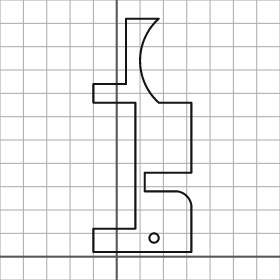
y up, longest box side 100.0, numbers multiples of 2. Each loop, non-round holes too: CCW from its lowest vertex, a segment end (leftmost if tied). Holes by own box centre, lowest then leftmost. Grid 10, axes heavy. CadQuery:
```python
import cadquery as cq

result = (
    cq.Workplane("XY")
    .moveTo(-10.0, 2.0)
    .lineTo(32.0, 2.0)
    .lineTo(32.0, 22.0)
    .threePointArc((30.0, 26.0), (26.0, 28.0))
    .lineTo(12.0, 28.0)
    .lineTo(12.0, 36.0)
    .lineTo(32.0, 36.0)
    .lineTo(32.0, 66.0)
    .lineTo(18.0, 66.0)
    .threePointArc((10.0, 84.0), (18.0, 102.0))
    .lineTo(4.0, 102.0)
    .lineTo(4.0, 74.0)
    .lineTo(-10.0, 74.0)
    .lineTo(-10.0, 66.0)
    .lineTo(8.0, 66.0)
    .lineTo(8.0, 12.0)
    .lineTo(-10.0, 12.0)
    .close()
    .moveTo(16.0, 8.0)
    .circle(2.0)
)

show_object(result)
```